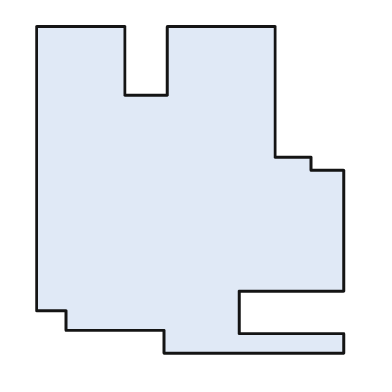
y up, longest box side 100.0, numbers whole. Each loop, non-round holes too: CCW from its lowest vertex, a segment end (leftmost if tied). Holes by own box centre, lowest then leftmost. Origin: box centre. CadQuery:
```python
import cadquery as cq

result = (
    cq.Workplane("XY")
    .moveTo(-8.0, -50.0)
    .lineTo(47.0, -50.0)
    .lineTo(47.0, -44.0)
    .lineTo(15.0, -44.0)
    .lineTo(15.0, -31.0)
    .lineTo(47.0, -31.0)
    .lineTo(47.0, 6.0)
    .lineTo(37.0, 6.0)
    .lineTo(37.0, 10.0)
    .lineTo(26.0, 10.0)
    .lineTo(26.0, 50.0)
    .lineTo(-7.0, 50.0)
    .lineTo(-7.0, 29.0)
    .lineTo(-20.0, 29.0)
    .lineTo(-20.0, 50.0)
    .lineTo(-47.0, 50.0)
    .lineTo(-47.0, -37.0)
    .lineTo(-38.0, -37.0)
    .lineTo(-38.0, -43.0)
    .lineTo(-8.0, -43.0)
    .close()
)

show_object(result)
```